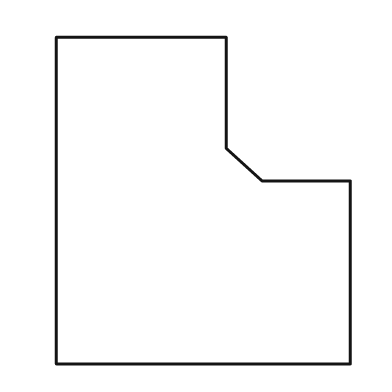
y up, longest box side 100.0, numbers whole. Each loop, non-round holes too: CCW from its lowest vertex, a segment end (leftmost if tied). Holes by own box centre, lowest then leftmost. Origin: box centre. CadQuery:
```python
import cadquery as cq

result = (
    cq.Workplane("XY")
    .moveTo(-45.0, -50.0)
    .lineTo(45.0, -50.0)
    .lineTo(45.0, 6.0)
    .lineTo(18.0, 6.0)
    .lineTo(7.0, 16.0)
    .lineTo(7.0, 50.0)
    .lineTo(-45.0, 50.0)
    .close()
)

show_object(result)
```